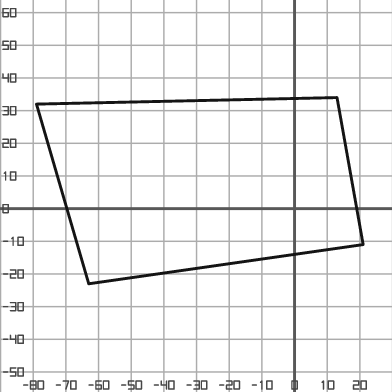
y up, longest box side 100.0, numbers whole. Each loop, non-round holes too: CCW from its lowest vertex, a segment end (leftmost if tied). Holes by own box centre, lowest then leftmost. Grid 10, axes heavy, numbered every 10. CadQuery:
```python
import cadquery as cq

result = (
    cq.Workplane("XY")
    .moveTo(-63.0, -23.0)
    .lineTo(21.0, -11.0)
    .lineTo(13.0, 34.0)
    .lineTo(-79.0, 32.0)
    .close()
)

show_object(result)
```